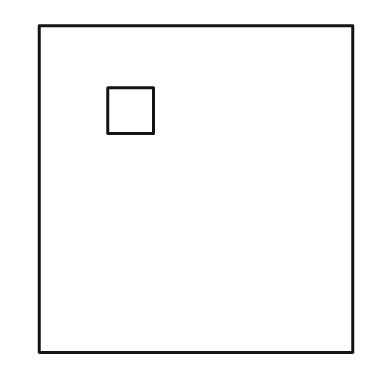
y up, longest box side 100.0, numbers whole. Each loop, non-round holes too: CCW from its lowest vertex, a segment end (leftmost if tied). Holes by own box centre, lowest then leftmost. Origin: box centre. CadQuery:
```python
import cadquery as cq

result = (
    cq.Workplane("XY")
    .moveTo(-48.0, -50.0)
    .lineTo(48.0, -50.0)
    .lineTo(48.0, 50.0)
    .lineTo(-48.0, 50.0)
    .close()
    .moveTo(-27.0, 17.0)
    .lineTo(-13.0, 17.0)
    .lineTo(-13.0, 31.0)
    .lineTo(-27.0, 31.0)
    .close()
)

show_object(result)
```